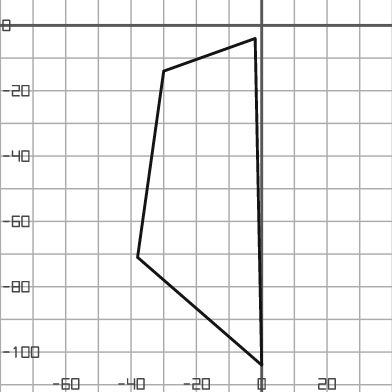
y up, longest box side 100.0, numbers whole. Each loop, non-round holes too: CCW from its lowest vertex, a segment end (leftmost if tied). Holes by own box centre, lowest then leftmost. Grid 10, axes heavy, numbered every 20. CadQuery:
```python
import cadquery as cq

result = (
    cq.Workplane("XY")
    .moveTo(0.0, -104.0)
    .lineTo(-2.0, -4.0)
    .lineTo(-30.0, -14.0)
    .lineTo(-38.0, -71.0)
    .close()
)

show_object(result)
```